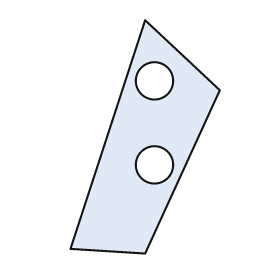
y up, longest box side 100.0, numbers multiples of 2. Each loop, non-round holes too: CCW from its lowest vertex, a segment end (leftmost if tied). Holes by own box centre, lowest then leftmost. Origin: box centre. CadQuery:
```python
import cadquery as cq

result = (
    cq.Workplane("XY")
    .moveTo(0.0, -50.0)
    .lineTo(32.0, 20.0)
    .lineTo(0.0, 50.0)
    .lineTo(-32.0, -48.0)
    .close()
    .moveTo(4.0, -12.0)
    .circle(8.0)
    .moveTo(4.0, 24.0)
    .circle(8.0)
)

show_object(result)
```